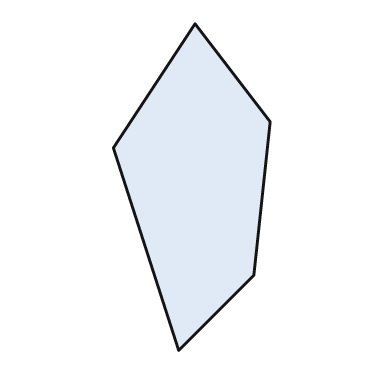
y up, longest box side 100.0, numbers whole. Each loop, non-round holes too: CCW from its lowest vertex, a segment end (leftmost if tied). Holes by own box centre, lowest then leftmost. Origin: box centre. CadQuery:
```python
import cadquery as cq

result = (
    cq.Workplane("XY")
    .moveTo(-4.0, -50.0)
    .lineTo(19.0, -27.0)
    .lineTo(24.0, 20.0)
    .lineTo(1.0, 50.0)
    .lineTo(-24.0, 12.0)
    .close()
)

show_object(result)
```